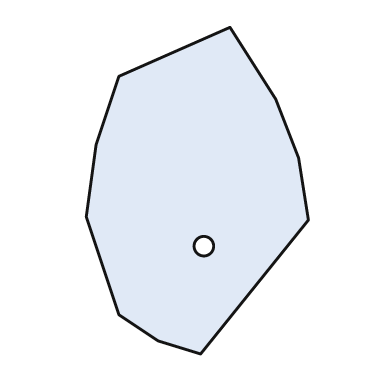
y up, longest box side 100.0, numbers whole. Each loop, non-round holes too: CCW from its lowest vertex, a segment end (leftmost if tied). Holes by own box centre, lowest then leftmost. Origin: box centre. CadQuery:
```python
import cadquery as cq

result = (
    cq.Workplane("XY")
    .moveTo(1.0, -50.0)
    .lineTo(34.0, -9.0)
    .lineTo(31.0, 10.0)
    .lineTo(24.0, 28.0)
    .lineTo(10.0, 50.0)
    .lineTo(-24.0, 35.0)
    .lineTo(-31.0, 14.0)
    .lineTo(-34.0, -8.0)
    .lineTo(-24.0, -38.0)
    .lineTo(-12.0, -46.0)
    .close()
    .moveTo(2.0, -17.0)
    .circle(3.0)
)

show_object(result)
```